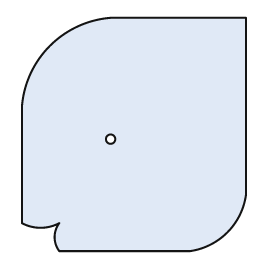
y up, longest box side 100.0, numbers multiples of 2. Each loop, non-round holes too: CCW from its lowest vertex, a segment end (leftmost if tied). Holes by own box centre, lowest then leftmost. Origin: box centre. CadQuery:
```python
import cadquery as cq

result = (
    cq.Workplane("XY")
    .moveTo(-32.0, -50.0)
    .lineTo(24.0, -50.0)
    .threePointArc((40.0, -42.0), (48.0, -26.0))
    .lineTo(48.0, 50.0)
    .lineTo(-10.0, 50.0)
    .threePointArc((-36.0, 38.0), (-48.0, 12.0))
    .lineTo(-48.0, -38.0)
    .threePointArc((-40.0, -40.0), (-32.0, -38.0))
    .threePointArc((-34.0, -44.0), (-32.0, -50.0))
    .close()
    .moveTo(-10.0, -2.0)
    .circle(2.0)
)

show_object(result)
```